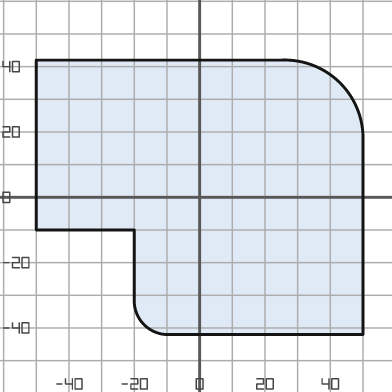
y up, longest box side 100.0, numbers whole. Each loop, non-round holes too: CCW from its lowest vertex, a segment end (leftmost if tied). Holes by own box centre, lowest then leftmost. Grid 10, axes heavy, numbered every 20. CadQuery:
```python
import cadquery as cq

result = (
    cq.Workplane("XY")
    .moveTo(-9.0, -42.0)
    .lineTo(50.0, -42.0)
    .lineTo(50.0, 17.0)
    .threePointArc((43.0, 35.0), (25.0, 42.0))
    .lineTo(-50.0, 42.0)
    .lineTo(-50.0, -10.0)
    .lineTo(-20.0, -10.0)
    .lineTo(-20.0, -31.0)
    .threePointArc((-17.0, -39.0), (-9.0, -42.0))
    .close()
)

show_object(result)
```